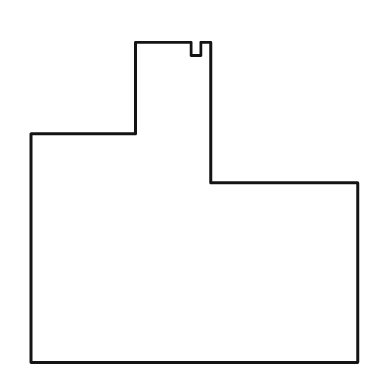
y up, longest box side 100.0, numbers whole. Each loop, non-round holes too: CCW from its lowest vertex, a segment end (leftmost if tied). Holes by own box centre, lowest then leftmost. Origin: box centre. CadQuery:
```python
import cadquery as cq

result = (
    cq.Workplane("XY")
    .moveTo(-50.0, -49.0)
    .lineTo(50.0, -49.0)
    .lineTo(50.0, 6.0)
    .lineTo(5.0, 6.0)
    .lineTo(5.0, 49.0)
    .lineTo(2.0, 49.0)
    .lineTo(2.0, 45.0)
    .lineTo(-1.0, 45.0)
    .lineTo(-1.0, 49.0)
    .lineTo(-18.0, 49.0)
    .lineTo(-18.0, 21.0)
    .lineTo(-50.0, 21.0)
    .close()
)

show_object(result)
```